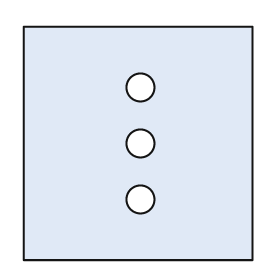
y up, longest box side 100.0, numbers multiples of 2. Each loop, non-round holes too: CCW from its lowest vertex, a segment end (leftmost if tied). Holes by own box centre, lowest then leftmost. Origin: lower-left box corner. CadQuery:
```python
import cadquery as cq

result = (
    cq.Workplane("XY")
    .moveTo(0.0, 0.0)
    .lineTo(98.0, 0.0)
    .lineTo(98.0, 100.0)
    .lineTo(0.0, 100.0)
    .close()
    .moveTo(50.0, 26.0)
    .circle(6.0)
    .moveTo(50.0, 50.0)
    .circle(6.0)
    .moveTo(50.0, 74.0)
    .circle(6.0)
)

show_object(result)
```